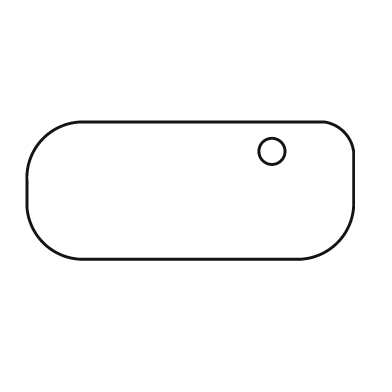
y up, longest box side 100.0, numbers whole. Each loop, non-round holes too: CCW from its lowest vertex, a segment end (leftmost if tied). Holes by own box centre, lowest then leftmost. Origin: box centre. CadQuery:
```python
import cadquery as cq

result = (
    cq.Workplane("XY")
    .moveTo(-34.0, -21.0)
    .lineTo(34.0, -21.0)
    .threePointArc((45.0, -16.0), (50.0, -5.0))
    .lineTo(50.0, 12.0)
    .threePointArc((47.0, 18.0), (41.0, 21.0))
    .lineTo(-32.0, 21.0)
    .threePointArc((-45.0, 16.0), (-50.0, 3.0))
    .lineTo(-50.0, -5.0)
    .threePointArc((-45.0, -16.0), (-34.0, -21.0))
    .close()
    .moveTo(25.0, 12.0)
    .circle(4.0)
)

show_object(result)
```